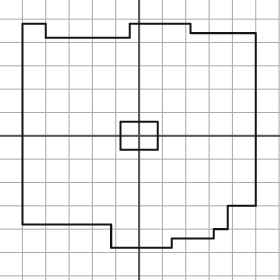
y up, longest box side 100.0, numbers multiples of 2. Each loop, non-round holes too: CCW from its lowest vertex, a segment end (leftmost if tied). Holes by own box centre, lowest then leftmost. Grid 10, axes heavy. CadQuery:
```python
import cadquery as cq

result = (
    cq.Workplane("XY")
    .moveTo(-12.0, -48.0)
    .lineTo(14.0, -48.0)
    .lineTo(14.0, -44.0)
    .lineTo(32.0, -44.0)
    .lineTo(32.0, -40.0)
    .lineTo(38.0, -40.0)
    .lineTo(38.0, -30.0)
    .lineTo(50.0, -30.0)
    .lineTo(50.0, 44.0)
    .lineTo(22.0, 44.0)
    .lineTo(22.0, 48.0)
    .lineTo(-4.0, 48.0)
    .lineTo(-4.0, 42.0)
    .lineTo(-40.0, 42.0)
    .lineTo(-40.0, 48.0)
    .lineTo(-50.0, 48.0)
    .lineTo(-50.0, -38.0)
    .lineTo(-12.0, -38.0)
    .close()
    .moveTo(-8.0, -6.0)
    .lineTo(8.0, -6.0)
    .lineTo(8.0, 6.0)
    .lineTo(-8.0, 6.0)
    .close()
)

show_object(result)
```